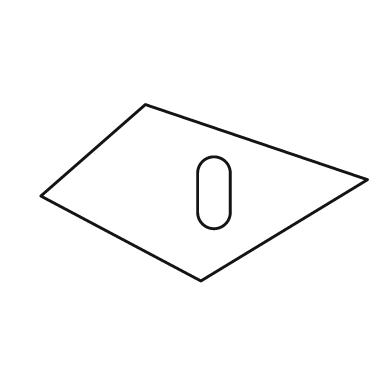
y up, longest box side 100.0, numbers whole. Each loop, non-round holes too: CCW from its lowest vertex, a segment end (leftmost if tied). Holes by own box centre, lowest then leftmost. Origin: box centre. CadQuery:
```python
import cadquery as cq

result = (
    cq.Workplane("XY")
    .moveTo(-1.0, -27.0)
    .lineTo(50.0, 4.0)
    .lineTo(-18.0, 27.0)
    .lineTo(-50.0, -1.0)
    .close()
    .moveTo(-2.0, -6.0)
    .threePointArc((3.0, -11.0), (8.0, -6.0))
    .lineTo(8.0, 6.0)
    .threePointArc((3.0, 11.0), (-2.0, 6.0))
    .close()
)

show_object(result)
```